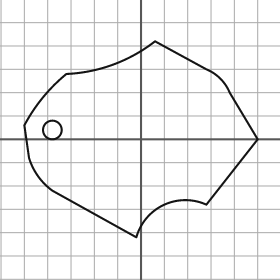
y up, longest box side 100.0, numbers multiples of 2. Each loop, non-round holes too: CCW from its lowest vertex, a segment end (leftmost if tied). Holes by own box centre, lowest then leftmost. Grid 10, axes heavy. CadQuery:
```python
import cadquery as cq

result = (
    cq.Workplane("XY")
    .moveTo(-2.0, -42.0)
    .threePointArc((10.0, -28.0), (28.0, -28.0))
    .lineTo(50.0, 0.0)
    .lineTo(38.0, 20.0)
    .threePointArc((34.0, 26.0), (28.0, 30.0))
    .lineTo(6.0, 42.0)
    .threePointArc((-12.0, 32.0), (-32.0, 28.0))
    .threePointArc((-42.0, 18.0), (-50.0, 6.0))
    .lineTo(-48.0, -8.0)
    .threePointArc((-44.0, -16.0), (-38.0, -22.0))
    .close()
    .moveTo(-38.0, 4.0)
    .circle(4.0)
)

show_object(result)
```